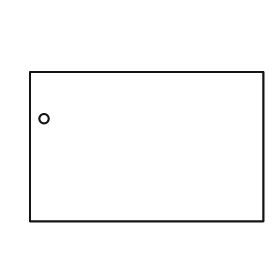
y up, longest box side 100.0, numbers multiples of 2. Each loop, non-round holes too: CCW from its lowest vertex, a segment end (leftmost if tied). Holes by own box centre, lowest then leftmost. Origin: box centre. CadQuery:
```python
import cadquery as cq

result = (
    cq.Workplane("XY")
    .moveTo(-50.0, -32.0)
    .lineTo(50.0, -32.0)
    .lineTo(50.0, 32.0)
    .lineTo(-50.0, 32.0)
    .close()
    .moveTo(-44.0, 12.0)
    .circle(2.0)
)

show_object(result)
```